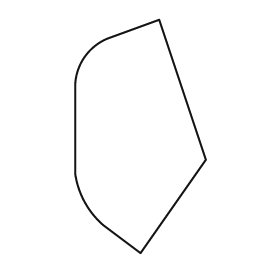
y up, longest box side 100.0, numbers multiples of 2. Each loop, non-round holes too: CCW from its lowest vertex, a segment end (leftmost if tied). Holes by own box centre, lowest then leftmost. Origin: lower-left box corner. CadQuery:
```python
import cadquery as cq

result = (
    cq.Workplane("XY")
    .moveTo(28.0, 0.0)
    .lineTo(56.0, 40.0)
    .lineTo(36.0, 100.0)
    .lineTo(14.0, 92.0)
    .threePointArc((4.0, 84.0), (0.0, 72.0))
    .lineTo(0.0, 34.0)
    .threePointArc((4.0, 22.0), (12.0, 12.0))
    .close()
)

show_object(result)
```